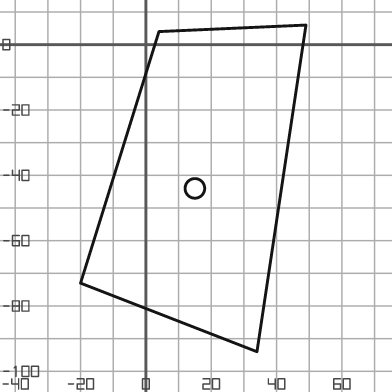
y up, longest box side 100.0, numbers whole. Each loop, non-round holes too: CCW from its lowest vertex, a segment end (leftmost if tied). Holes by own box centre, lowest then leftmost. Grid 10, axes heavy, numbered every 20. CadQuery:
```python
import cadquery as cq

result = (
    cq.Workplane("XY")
    .moveTo(34.0, -94.0)
    .lineTo(49.0, 6.0)
    .lineTo(4.0, 4.0)
    .lineTo(-20.0, -73.0)
    .close()
    .moveTo(15.0, -44.0)
    .circle(3.0)
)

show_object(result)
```